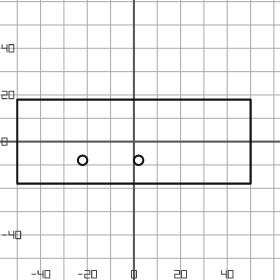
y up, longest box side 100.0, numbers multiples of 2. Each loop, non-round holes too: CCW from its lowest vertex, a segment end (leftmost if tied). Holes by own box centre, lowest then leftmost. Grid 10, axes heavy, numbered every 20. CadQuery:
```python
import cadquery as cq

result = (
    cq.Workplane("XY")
    .moveTo(-50.0, -18.0)
    .lineTo(50.0, -18.0)
    .lineTo(50.0, 18.0)
    .lineTo(-50.0, 18.0)
    .close()
    .moveTo(-22.0, -8.0)
    .circle(2.0)
    .moveTo(2.0, -8.0)
    .circle(2.0)
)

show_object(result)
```